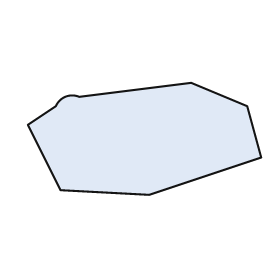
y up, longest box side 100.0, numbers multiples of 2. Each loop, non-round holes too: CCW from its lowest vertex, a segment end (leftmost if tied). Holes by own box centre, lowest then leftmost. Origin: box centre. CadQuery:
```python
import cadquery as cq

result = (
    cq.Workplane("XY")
    .moveTo(2.0, -24.0)
    .lineTo(50.0, -8.0)
    .lineTo(44.0, 14.0)
    .lineTo(20.0, 24.0)
    .lineTo(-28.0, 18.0)
    .threePointArc((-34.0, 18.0), (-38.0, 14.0))
    .lineTo(-50.0, 6.0)
    .lineTo(-36.0, -22.0)
    .close()
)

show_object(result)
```